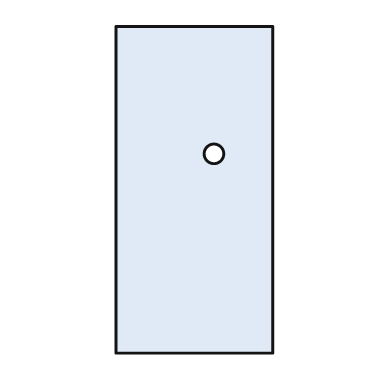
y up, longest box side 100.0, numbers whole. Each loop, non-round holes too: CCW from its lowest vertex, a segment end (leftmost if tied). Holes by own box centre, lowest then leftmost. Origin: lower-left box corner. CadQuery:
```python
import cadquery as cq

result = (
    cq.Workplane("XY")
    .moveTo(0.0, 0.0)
    .lineTo(48.0, 0.0)
    .lineTo(48.0, 100.0)
    .lineTo(0.0, 100.0)
    .close()
    .moveTo(30.0, 61.0)
    .circle(3.0)
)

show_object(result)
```